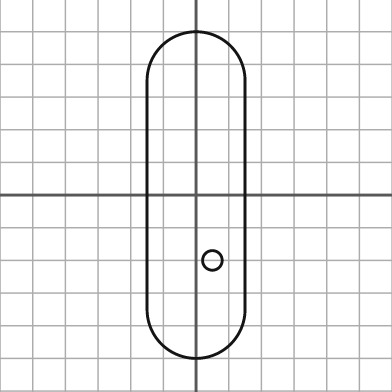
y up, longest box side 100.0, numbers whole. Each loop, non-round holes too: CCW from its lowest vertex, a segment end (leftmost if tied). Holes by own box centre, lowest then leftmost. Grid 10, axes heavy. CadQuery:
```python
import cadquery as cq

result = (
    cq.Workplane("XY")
    .moveTo(-15.0, -35.0)
    .threePointArc((0.0, -50.0), (15.0, -35.0))
    .lineTo(15.0, 35.0)
    .threePointArc((0.0, 50.0), (-15.0, 35.0))
    .close()
    .moveTo(5.0, -20.0)
    .circle(3.0)
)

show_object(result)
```